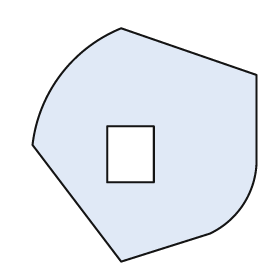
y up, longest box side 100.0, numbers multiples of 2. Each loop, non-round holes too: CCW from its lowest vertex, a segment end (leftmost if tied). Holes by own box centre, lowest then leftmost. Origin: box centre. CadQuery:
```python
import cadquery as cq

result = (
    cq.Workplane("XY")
    .moveTo(-10.0, -50.0)
    .lineTo(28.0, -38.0)
    .threePointArc((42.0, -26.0), (48.0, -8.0))
    .lineTo(48.0, 30.0)
    .lineTo(-10.0, 50.0)
    .threePointArc((-36.0, 30.0), (-48.0, 0.0))
    .close()
    .moveTo(-16.0, -16.0)
    .lineTo(4.0, -16.0)
    .lineTo(4.0, 8.0)
    .lineTo(-16.0, 8.0)
    .close()
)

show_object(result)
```